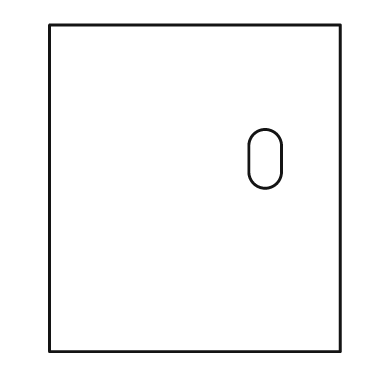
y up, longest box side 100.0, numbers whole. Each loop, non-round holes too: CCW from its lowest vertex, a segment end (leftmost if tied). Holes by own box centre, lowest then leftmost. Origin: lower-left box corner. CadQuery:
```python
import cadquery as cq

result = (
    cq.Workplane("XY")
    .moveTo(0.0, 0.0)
    .lineTo(89.0, 0.0)
    .lineTo(89.0, 100.0)
    .lineTo(0.0, 100.0)
    .close()
    .moveTo(61.0, 55.0)
    .threePointArc((66.0, 50.0), (71.0, 55.0))
    .lineTo(71.0, 63.0)
    .threePointArc((66.0, 68.0), (61.0, 63.0))
    .close()
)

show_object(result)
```